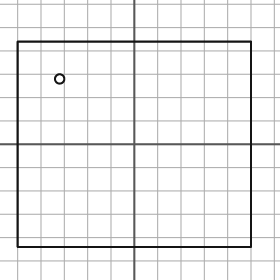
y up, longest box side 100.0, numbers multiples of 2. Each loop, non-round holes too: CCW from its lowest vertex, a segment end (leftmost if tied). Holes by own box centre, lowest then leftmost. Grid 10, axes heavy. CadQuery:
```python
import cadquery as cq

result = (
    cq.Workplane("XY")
    .moveTo(-50.0, -44.0)
    .lineTo(50.0, -44.0)
    .lineTo(50.0, 44.0)
    .lineTo(-50.0, 44.0)
    .close()
    .moveTo(-32.0, 28.0)
    .circle(2.0)
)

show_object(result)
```